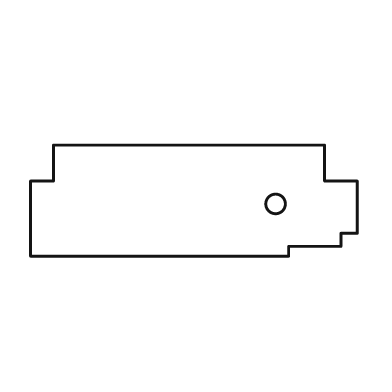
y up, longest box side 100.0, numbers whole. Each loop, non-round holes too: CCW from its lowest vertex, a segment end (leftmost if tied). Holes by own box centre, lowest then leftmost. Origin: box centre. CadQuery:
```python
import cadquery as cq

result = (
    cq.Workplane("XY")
    .moveTo(-50.0, -17.0)
    .lineTo(29.0, -17.0)
    .lineTo(29.0, -14.0)
    .lineTo(45.0, -14.0)
    .lineTo(45.0, -10.0)
    .lineTo(50.0, -10.0)
    .lineTo(50.0, 6.0)
    .lineTo(40.0, 6.0)
    .lineTo(40.0, 17.0)
    .lineTo(-43.0, 17.0)
    .lineTo(-43.0, 6.0)
    .lineTo(-50.0, 6.0)
    .close()
    .moveTo(25.0, -1.0)
    .circle(3.0)
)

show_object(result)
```